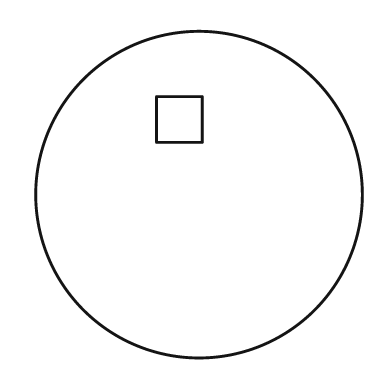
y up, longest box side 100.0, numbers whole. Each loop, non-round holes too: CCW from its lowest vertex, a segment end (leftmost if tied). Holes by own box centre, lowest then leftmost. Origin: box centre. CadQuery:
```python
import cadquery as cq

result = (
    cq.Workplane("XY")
    .moveTo(0.0, 0.0)
    .circle(50.0)
    .moveTo(-13.0, 16.0)
    .lineTo(1.0, 16.0)
    .lineTo(1.0, 30.0)
    .lineTo(-13.0, 30.0)
    .close()
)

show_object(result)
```